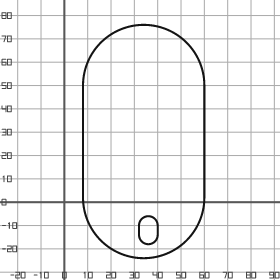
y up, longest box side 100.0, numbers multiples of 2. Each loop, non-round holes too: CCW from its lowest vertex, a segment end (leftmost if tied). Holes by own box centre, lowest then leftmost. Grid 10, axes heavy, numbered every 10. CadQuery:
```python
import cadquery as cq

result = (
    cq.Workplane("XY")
    .moveTo(8.0, 2.0)
    .threePointArc((34.0, -24.0), (60.0, 2.0))
    .lineTo(60.0, 50.0)
    .threePointArc((34.0, 76.0), (8.0, 50.0))
    .close()
    .moveTo(32.0, -14.0)
    .threePointArc((36.0, -18.0), (40.0, -14.0))
    .lineTo(40.0, -10.0)
    .threePointArc((36.0, -6.0), (32.0, -10.0))
    .close()
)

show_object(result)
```